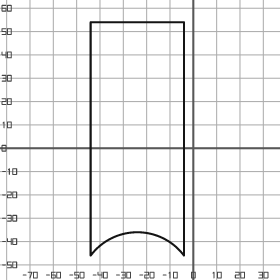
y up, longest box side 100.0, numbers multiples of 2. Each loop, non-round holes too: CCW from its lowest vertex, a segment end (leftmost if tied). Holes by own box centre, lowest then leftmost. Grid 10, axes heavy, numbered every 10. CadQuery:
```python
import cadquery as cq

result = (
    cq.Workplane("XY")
    .moveTo(-44.0, -46.0)
    .threePointArc((-24.0, -36.0), (-4.0, -46.0))
    .lineTo(-4.0, 54.0)
    .lineTo(-44.0, 54.0)
    .close()
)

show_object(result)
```